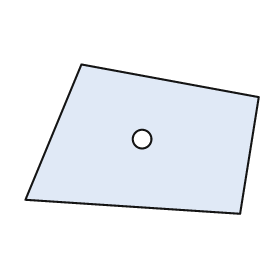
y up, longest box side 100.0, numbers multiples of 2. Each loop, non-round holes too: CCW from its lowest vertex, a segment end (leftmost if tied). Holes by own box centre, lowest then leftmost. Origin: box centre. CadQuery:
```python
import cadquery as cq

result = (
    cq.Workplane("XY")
    .moveTo(42.0, -32.0)
    .lineTo(50.0, 18.0)
    .lineTo(-26.0, 32.0)
    .lineTo(-50.0, -26.0)
    .close()
    .moveTo(0.0, 0.0)
    .circle(4.0)
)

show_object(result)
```